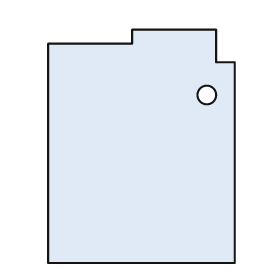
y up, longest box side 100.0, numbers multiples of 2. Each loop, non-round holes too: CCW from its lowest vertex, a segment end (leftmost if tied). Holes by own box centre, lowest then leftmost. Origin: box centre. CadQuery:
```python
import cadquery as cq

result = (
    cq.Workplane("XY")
    .moveTo(-40.0, -50.0)
    .lineTo(40.0, -50.0)
    .lineTo(40.0, 36.0)
    .lineTo(32.0, 36.0)
    .lineTo(32.0, 50.0)
    .lineTo(-4.0, 50.0)
    .lineTo(-4.0, 44.0)
    .lineTo(-40.0, 44.0)
    .close()
    .moveTo(28.0, 22.0)
    .circle(4.0)
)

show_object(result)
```